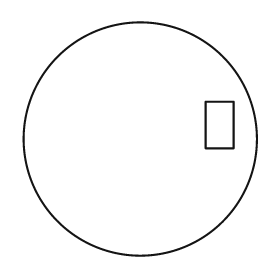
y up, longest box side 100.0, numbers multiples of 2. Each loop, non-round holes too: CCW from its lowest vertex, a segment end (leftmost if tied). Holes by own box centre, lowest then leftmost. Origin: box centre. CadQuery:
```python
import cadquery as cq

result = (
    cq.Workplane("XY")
    .moveTo(0.0, 0.0)
    .circle(50.0)
    .moveTo(28.0, -4.0)
    .lineTo(40.0, -4.0)
    .lineTo(40.0, 16.0)
    .lineTo(28.0, 16.0)
    .close()
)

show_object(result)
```